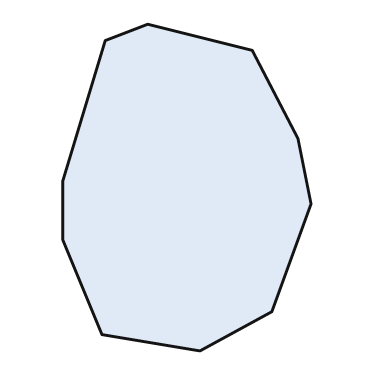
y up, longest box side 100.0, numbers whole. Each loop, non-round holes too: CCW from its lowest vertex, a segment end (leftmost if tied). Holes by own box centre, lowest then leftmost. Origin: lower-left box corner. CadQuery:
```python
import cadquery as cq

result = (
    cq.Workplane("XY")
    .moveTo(42.0, 0.0)
    .lineTo(64.0, 12.0)
    .lineTo(76.0, 45.0)
    .lineTo(72.0, 65.0)
    .lineTo(58.0, 92.0)
    .lineTo(26.0, 100.0)
    .lineTo(13.0, 95.0)
    .lineTo(0.0, 52.0)
    .lineTo(0.0, 34.0)
    .lineTo(12.0, 5.0)
    .close()
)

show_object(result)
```